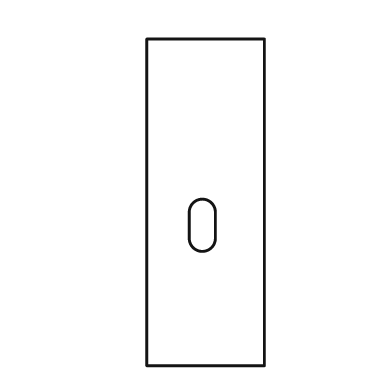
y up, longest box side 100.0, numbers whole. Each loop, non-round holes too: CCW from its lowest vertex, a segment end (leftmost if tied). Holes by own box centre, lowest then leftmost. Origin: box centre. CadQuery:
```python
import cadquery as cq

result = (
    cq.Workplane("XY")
    .moveTo(-18.0, -50.0)
    .lineTo(18.0, -50.0)
    .lineTo(18.0, 50.0)
    .lineTo(-18.0, 50.0)
    .close()
    .moveTo(-5.0, -11.0)
    .threePointArc((-1.0, -15.0), (3.0, -11.0))
    .lineTo(3.0, -3.0)
    .threePointArc((-1.0, 1.0), (-5.0, -3.0))
    .close()
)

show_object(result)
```